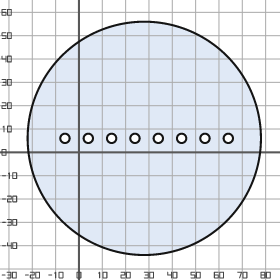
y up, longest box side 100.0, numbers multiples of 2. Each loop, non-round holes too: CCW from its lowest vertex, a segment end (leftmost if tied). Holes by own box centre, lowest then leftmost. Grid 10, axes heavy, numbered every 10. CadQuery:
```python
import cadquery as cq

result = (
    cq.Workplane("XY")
    .moveTo(28.0, 6.0)
    .circle(50.0)
    .moveTo(-6.0, 6.0)
    .circle(2.0)
    .moveTo(4.0, 6.0)
    .circle(2.0)
    .moveTo(14.0, 6.0)
    .circle(2.0)
    .moveTo(24.0, 6.0)
    .circle(2.0)
    .moveTo(34.0, 6.0)
    .circle(2.0)
    .moveTo(44.0, 6.0)
    .circle(2.0)
    .moveTo(54.0, 6.0)
    .circle(2.0)
    .moveTo(64.0, 6.0)
    .circle(2.0)
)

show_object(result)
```